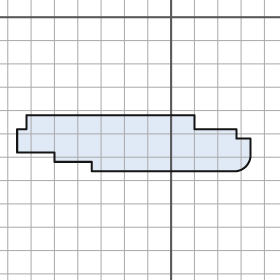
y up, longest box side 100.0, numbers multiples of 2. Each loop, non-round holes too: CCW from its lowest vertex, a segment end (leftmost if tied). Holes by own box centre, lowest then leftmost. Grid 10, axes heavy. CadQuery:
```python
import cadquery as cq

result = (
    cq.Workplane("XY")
    .moveTo(-34.0, -66.0)
    .lineTo(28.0, -66.0)
    .threePointArc((32.0, -64.0), (34.0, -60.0))
    .lineTo(34.0, -52.0)
    .lineTo(28.0, -52.0)
    .lineTo(28.0, -48.0)
    .lineTo(10.0, -48.0)
    .lineTo(10.0, -42.0)
    .lineTo(-62.0, -42.0)
    .lineTo(-62.0, -48.0)
    .lineTo(-66.0, -48.0)
    .lineTo(-66.0, -58.0)
    .lineTo(-50.0, -58.0)
    .lineTo(-50.0, -62.0)
    .lineTo(-34.0, -62.0)
    .close()
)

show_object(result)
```